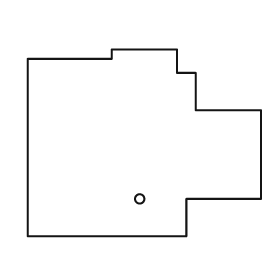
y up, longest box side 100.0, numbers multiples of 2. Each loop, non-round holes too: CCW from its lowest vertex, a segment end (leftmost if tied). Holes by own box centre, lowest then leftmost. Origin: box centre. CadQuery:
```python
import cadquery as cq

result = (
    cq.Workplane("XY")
    .moveTo(-50.0, -40.0)
    .lineTo(18.0, -40.0)
    .lineTo(18.0, -24.0)
    .lineTo(50.0, -24.0)
    .lineTo(50.0, 14.0)
    .lineTo(22.0, 14.0)
    .lineTo(22.0, 30.0)
    .lineTo(14.0, 30.0)
    .lineTo(14.0, 40.0)
    .lineTo(-14.0, 40.0)
    .lineTo(-14.0, 36.0)
    .lineTo(-50.0, 36.0)
    .close()
    .moveTo(-2.0, -24.0)
    .circle(2.0)
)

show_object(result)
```